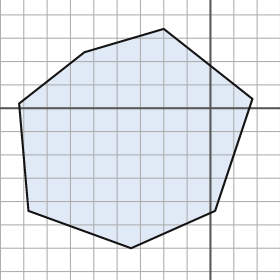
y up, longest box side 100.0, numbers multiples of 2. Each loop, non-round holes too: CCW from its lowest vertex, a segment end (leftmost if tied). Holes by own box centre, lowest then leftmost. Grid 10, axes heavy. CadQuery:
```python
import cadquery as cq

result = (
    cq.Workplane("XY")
    .moveTo(-34.0, -60.0)
    .lineTo(2.0, -44.0)
    .lineTo(18.0, 4.0)
    .lineTo(-20.0, 34.0)
    .lineTo(-54.0, 24.0)
    .lineTo(-82.0, 2.0)
    .lineTo(-78.0, -44.0)
    .close()
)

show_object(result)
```